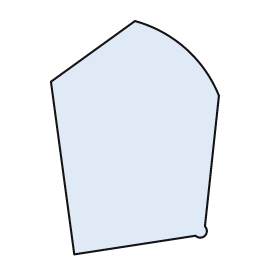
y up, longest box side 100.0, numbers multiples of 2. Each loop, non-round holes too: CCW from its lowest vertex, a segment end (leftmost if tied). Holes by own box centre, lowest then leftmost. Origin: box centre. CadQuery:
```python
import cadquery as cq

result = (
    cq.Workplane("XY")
    .moveTo(-26.0, -50.0)
    .lineTo(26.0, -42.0)
    .threePointArc((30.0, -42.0), (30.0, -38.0))
    .lineTo(36.0, 18.0)
    .threePointArc((22.0, 38.0), (0.0, 50.0))
    .lineTo(-36.0, 24.0)
    .close()
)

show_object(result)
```